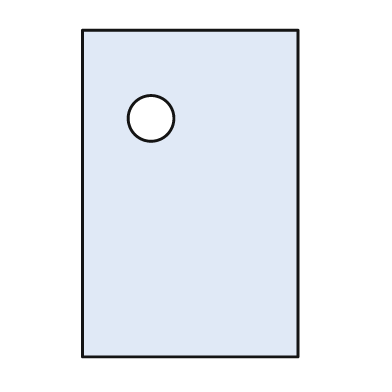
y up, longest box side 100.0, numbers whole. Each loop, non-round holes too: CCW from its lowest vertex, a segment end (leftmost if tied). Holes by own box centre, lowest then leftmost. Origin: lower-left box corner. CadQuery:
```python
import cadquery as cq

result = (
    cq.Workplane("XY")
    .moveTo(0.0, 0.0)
    .lineTo(66.0, 0.0)
    .lineTo(66.0, 100.0)
    .lineTo(0.0, 100.0)
    .close()
    .moveTo(21.0, 73.0)
    .circle(7.0)
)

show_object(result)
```